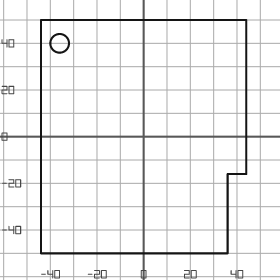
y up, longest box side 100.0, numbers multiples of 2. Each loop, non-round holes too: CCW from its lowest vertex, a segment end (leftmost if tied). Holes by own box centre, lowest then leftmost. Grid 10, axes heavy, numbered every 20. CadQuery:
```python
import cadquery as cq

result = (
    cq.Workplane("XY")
    .moveTo(-44.0, -50.0)
    .lineTo(36.0, -50.0)
    .lineTo(36.0, -16.0)
    .lineTo(44.0, -16.0)
    .lineTo(44.0, 50.0)
    .lineTo(-44.0, 50.0)
    .close()
    .moveTo(-36.0, 40.0)
    .circle(4.0)
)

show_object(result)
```